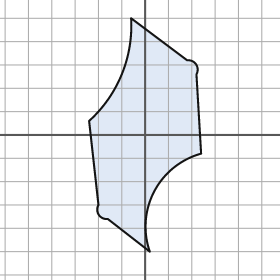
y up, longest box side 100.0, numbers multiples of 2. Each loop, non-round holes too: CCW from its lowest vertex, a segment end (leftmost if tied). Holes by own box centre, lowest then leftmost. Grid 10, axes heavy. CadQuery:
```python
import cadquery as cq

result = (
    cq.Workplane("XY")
    .moveTo(2.0, -50.0)
    .threePointArc((4.0, -24.0), (24.0, -8.0))
    .lineTo(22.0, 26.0)
    .threePointArc((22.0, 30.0), (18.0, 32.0))
    .lineTo(-6.0, 50.0)
    .threePointArc((-10.0, 26.0), (-24.0, 6.0))
    .lineTo(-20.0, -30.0)
    .threePointArc((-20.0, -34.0), (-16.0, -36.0))
    .close()
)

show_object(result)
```